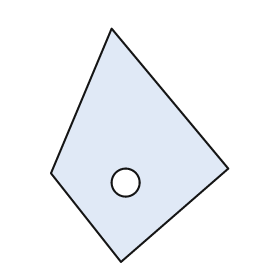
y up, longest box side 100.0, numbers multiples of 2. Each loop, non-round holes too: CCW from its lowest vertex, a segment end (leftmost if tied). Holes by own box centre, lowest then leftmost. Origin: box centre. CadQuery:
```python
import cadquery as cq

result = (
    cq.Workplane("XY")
    .moveTo(-8.0, -50.0)
    .lineTo(38.0, -10.0)
    .lineTo(-12.0, 50.0)
    .lineTo(-38.0, -12.0)
    .close()
    .moveTo(-6.0, -16.0)
    .circle(6.0)
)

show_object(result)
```